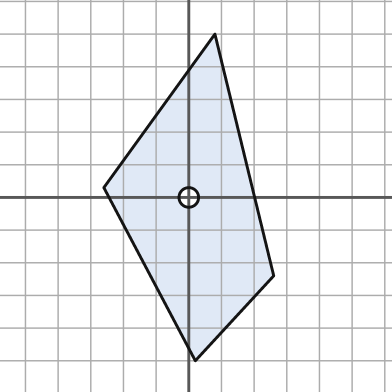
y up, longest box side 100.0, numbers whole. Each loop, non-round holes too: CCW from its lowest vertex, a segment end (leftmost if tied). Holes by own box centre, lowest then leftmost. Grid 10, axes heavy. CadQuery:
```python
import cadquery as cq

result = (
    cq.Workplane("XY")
    .moveTo(2.0, -50.0)
    .lineTo(26.0, -24.0)
    .lineTo(8.0, 50.0)
    .lineTo(-26.0, 3.0)
    .close()
    .moveTo(0.0, 0.0)
    .circle(3.0)
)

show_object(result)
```